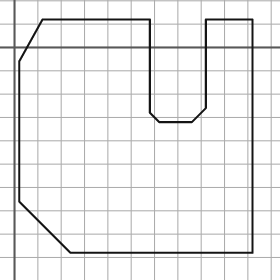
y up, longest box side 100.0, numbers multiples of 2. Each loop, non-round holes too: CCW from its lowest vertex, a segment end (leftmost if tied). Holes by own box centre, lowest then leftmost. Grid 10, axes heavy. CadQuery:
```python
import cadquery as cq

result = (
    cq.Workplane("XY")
    .moveTo(24.0, -88.0)
    .lineTo(102.0, -88.0)
    .lineTo(102.0, 12.0)
    .lineTo(82.0, 12.0)
    .lineTo(82.0, -26.0)
    .lineTo(76.0, -32.0)
    .lineTo(62.0, -32.0)
    .lineTo(58.0, -28.0)
    .lineTo(58.0, 12.0)
    .lineTo(12.0, 12.0)
    .lineTo(2.0, -6.0)
    .lineTo(2.0, -66.0)
    .close()
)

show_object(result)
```